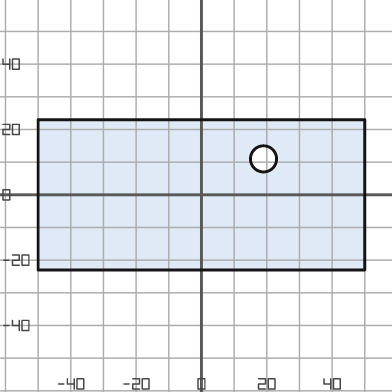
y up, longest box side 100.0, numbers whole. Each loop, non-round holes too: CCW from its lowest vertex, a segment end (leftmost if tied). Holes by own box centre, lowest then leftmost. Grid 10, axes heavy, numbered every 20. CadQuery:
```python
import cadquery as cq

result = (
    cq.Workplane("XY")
    .moveTo(-50.0, -23.0)
    .lineTo(50.0, -23.0)
    .lineTo(50.0, 23.0)
    .lineTo(-50.0, 23.0)
    .close()
    .moveTo(19.0, 11.0)
    .circle(4.0)
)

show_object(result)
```